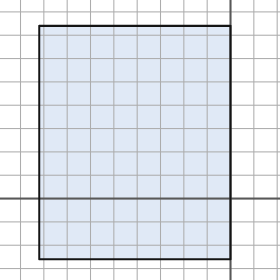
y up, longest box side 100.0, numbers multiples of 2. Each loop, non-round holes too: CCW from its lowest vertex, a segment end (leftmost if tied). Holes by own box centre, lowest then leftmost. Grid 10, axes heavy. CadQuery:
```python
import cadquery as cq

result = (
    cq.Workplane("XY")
    .moveTo(-82.0, -26.0)
    .lineTo(0.0, -26.0)
    .lineTo(0.0, 74.0)
    .lineTo(-82.0, 74.0)
    .close()
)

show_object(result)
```